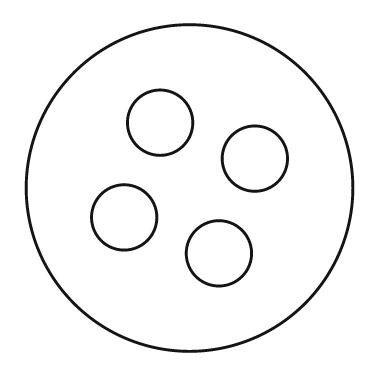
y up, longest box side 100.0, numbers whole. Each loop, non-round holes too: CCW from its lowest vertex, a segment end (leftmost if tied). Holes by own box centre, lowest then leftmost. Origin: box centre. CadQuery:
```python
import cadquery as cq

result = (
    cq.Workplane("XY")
    .moveTo(0.0, 0.0)
    .circle(50.0)
    .moveTo(9.0, -20.0)
    .circle(10.0)
    .moveTo(-20.0, -9.0)
    .circle(10.0)
    .moveTo(20.0, 9.0)
    .circle(10.0)
    .moveTo(-9.0, 20.0)
    .circle(10.0)
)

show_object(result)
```